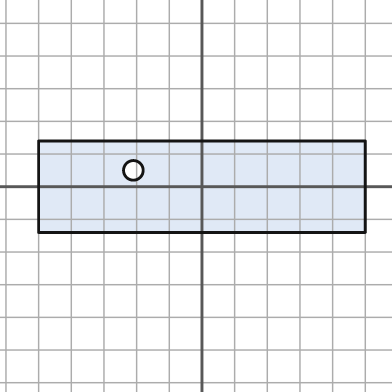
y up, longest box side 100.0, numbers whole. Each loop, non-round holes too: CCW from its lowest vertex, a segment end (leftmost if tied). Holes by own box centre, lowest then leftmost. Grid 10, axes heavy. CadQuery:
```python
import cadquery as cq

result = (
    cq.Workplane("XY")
    .moveTo(-50.0, -14.0)
    .lineTo(50.0, -14.0)
    .lineTo(50.0, 14.0)
    .lineTo(-50.0, 14.0)
    .close()
    .moveTo(-21.0, 5.0)
    .circle(3.0)
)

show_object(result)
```